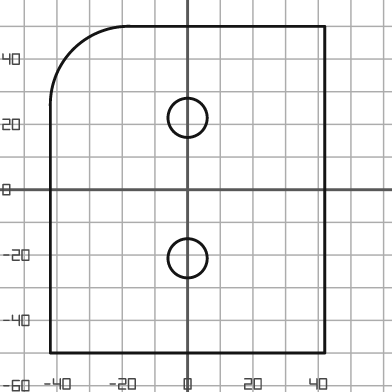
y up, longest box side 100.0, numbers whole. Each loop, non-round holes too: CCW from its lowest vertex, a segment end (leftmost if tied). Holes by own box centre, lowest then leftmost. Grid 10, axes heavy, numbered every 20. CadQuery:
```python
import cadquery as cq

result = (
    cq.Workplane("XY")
    .moveTo(-42.0, -50.0)
    .lineTo(42.0, -50.0)
    .lineTo(42.0, 50.0)
    .lineTo(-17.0, 50.0)
    .threePointArc((-35.0, 43.0), (-42.0, 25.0))
    .close()
    .moveTo(0.0, -21.0)
    .circle(6.0)
    .moveTo(0.0, 22.0)
    .circle(6.0)
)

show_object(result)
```